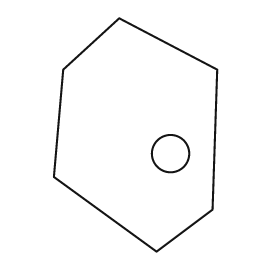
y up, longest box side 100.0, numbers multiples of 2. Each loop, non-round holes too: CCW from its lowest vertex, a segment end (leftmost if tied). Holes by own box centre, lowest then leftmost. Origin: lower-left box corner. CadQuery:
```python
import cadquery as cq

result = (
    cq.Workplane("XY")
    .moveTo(44.0, 0.0)
    .lineTo(68.0, 18.0)
    .lineTo(70.0, 78.0)
    .lineTo(28.0, 100.0)
    .lineTo(4.0, 78.0)
    .lineTo(0.0, 32.0)
    .close()
    .moveTo(50.0, 42.0)
    .circle(8.0)
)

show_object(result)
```